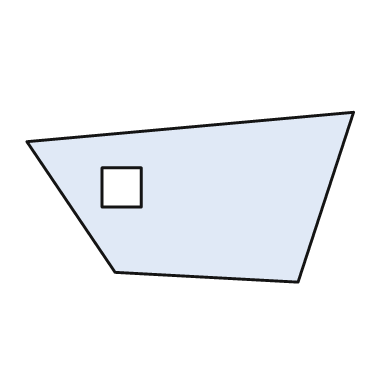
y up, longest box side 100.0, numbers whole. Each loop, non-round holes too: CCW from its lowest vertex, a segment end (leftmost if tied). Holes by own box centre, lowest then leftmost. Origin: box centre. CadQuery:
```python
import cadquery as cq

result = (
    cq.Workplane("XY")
    .moveTo(33.0, -26.0)
    .lineTo(50.0, 26.0)
    .lineTo(-50.0, 17.0)
    .lineTo(-23.0, -23.0)
    .close()
    .moveTo(-27.0, -3.0)
    .lineTo(-15.0, -3.0)
    .lineTo(-15.0, 9.0)
    .lineTo(-27.0, 9.0)
    .close()
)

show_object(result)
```